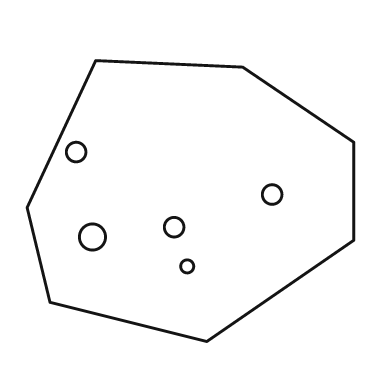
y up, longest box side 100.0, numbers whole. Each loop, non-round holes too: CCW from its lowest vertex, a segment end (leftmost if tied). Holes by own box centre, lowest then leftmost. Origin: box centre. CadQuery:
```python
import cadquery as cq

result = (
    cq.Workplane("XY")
    .moveTo(5.0, -43.0)
    .lineTo(50.0, -12.0)
    .lineTo(50.0, 18.0)
    .lineTo(16.0, 41.0)
    .lineTo(-29.0, 43.0)
    .lineTo(-50.0, -2.0)
    .lineTo(-43.0, -31.0)
    .close()
    .moveTo(-1.0, -20.0)
    .circle(2.0)
    .moveTo(-30.0, -11.0)
    .circle(4.0)
    .moveTo(-5.0, -8.0)
    .circle(3.0)
    .moveTo(25.0, 2.0)
    .circle(3.0)
    .moveTo(-35.0, 15.0)
    .circle(3.0)
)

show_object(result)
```